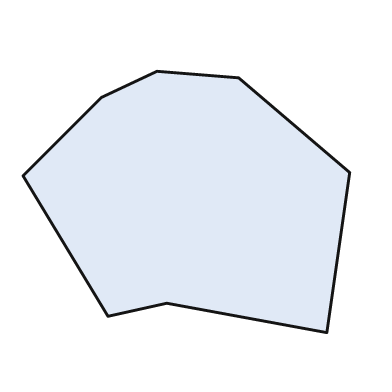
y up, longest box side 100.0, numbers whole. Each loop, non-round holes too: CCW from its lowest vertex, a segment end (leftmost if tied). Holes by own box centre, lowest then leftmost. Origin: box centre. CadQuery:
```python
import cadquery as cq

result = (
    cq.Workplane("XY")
    .moveTo(43.0, -40.0)
    .lineTo(50.0, 9.0)
    .lineTo(16.0, 38.0)
    .lineTo(-9.0, 40.0)
    .lineTo(-26.0, 32.0)
    .lineTo(-50.0, 8.0)
    .lineTo(-24.0, -35.0)
    .lineTo(-6.0, -31.0)
    .close()
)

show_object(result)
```